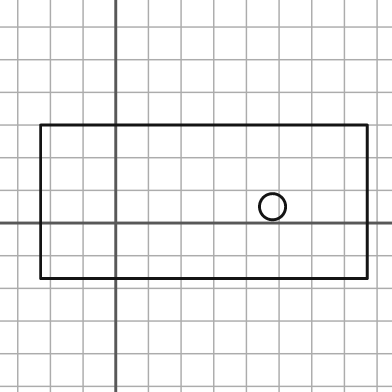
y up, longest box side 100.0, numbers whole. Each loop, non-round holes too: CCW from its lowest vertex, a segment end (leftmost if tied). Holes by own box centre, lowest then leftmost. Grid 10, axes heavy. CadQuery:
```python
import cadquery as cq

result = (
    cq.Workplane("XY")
    .moveTo(-23.0, -17.0)
    .lineTo(77.0, -17.0)
    .lineTo(77.0, 30.0)
    .lineTo(-23.0, 30.0)
    .close()
    .moveTo(48.0, 5.0)
    .circle(4.0)
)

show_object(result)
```